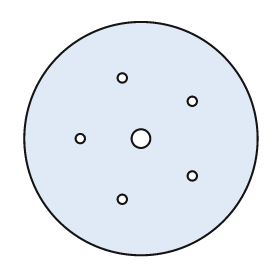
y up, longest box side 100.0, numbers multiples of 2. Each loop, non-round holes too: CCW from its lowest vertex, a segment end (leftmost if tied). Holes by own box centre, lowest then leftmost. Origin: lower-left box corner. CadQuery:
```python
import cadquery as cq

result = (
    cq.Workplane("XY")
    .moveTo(50.0, 50.0)
    .circle(50.0)
    .moveTo(42.0, 24.0)
    .circle(2.0)
    .moveTo(72.0, 34.0)
    .circle(2.0)
    .moveTo(24.0, 50.0)
    .circle(2.0)
    .moveTo(50.0, 50.0)
    .circle(4.0)
    .moveTo(72.0, 66.0)
    .circle(2.0)
    .moveTo(42.0, 76.0)
    .circle(2.0)
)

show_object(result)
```